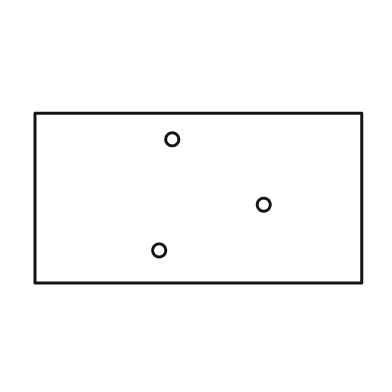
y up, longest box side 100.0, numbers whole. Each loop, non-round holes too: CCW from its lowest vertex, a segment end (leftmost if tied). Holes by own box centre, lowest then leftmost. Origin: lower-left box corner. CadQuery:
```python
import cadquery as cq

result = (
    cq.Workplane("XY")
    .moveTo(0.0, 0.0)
    .lineTo(100.0, 0.0)
    .lineTo(100.0, 52.0)
    .lineTo(0.0, 52.0)
    .close()
    .moveTo(38.0, 10.0)
    .circle(2.0)
    .moveTo(70.0, 24.0)
    .circle(2.0)
    .moveTo(42.0, 44.0)
    .circle(2.0)
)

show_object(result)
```